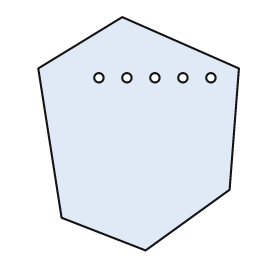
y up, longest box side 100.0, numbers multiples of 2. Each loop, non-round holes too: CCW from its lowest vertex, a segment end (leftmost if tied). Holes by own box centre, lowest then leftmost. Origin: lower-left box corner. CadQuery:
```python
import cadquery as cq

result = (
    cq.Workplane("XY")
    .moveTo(46.0, 0.0)
    .lineTo(82.0, 26.0)
    .lineTo(86.0, 78.0)
    .lineTo(36.0, 100.0)
    .lineTo(0.0, 78.0)
    .lineTo(10.0, 14.0)
    .close()
    .moveTo(26.0, 74.0)
    .circle(2.0)
    .moveTo(38.0, 74.0)
    .circle(2.0)
    .moveTo(50.0, 74.0)
    .circle(2.0)
    .moveTo(62.0, 74.0)
    .circle(2.0)
    .moveTo(74.0, 74.0)
    .circle(2.0)
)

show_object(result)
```